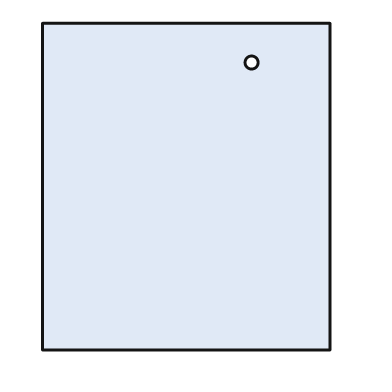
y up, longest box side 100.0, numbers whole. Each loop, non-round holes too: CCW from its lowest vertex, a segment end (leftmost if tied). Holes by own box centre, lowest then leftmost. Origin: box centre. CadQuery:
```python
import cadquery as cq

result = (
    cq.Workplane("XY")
    .moveTo(-44.0, -50.0)
    .lineTo(44.0, -50.0)
    .lineTo(44.0, 50.0)
    .lineTo(-44.0, 50.0)
    .close()
    .moveTo(20.0, 38.0)
    .circle(2.0)
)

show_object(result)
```